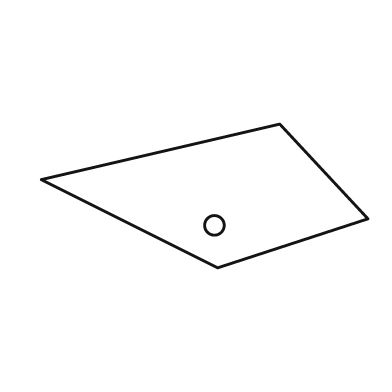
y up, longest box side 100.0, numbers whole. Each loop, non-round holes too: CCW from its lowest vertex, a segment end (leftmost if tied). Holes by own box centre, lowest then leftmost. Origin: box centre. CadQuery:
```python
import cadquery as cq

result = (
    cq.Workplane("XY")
    .moveTo(4.0, -22.0)
    .lineTo(50.0, -7.0)
    .lineTo(23.0, 22.0)
    .lineTo(-50.0, 5.0)
    .close()
    .moveTo(3.0, -9.0)
    .circle(3.0)
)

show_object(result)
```